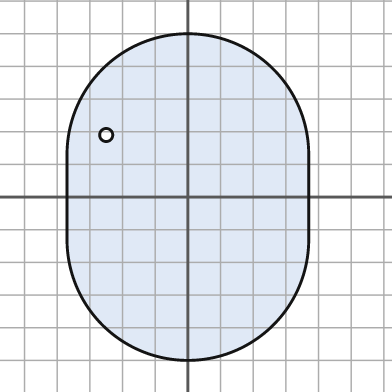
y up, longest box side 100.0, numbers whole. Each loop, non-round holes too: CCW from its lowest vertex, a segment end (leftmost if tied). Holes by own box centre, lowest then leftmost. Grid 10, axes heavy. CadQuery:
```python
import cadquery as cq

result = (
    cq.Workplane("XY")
    .moveTo(-37.0, -13.0)
    .threePointArc((0.0, -50.0), (37.0, -13.0))
    .lineTo(37.0, 13.0)
    .threePointArc((0.0, 50.0), (-37.0, 13.0))
    .close()
    .moveTo(-25.0, 19.0)
    .circle(2.0)
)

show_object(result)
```